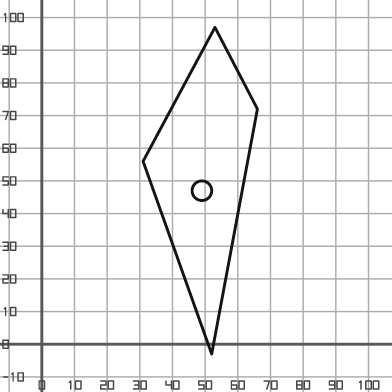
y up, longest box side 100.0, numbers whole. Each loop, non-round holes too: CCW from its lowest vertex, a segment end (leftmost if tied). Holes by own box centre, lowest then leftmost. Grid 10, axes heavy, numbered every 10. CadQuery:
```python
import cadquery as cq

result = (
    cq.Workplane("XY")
    .moveTo(52.0, -3.0)
    .lineTo(66.0, 72.0)
    .lineTo(53.0, 97.0)
    .lineTo(31.0, 56.0)
    .close()
    .moveTo(49.0, 47.0)
    .circle(3.0)
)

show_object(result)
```